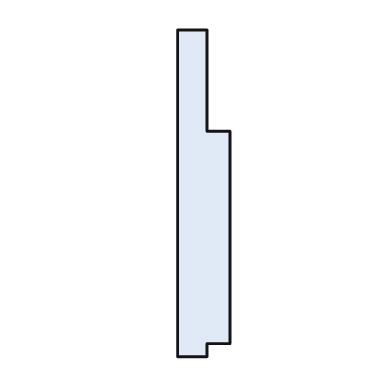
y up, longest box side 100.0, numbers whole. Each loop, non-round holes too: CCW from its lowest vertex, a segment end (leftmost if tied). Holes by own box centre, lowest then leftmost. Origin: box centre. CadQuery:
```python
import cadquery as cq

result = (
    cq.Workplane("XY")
    .moveTo(-8.0, -50.0)
    .lineTo(1.0, -50.0)
    .lineTo(1.0, -46.0)
    .lineTo(8.0, -46.0)
    .lineTo(8.0, 19.0)
    .lineTo(1.0, 19.0)
    .lineTo(1.0, 50.0)
    .lineTo(-8.0, 50.0)
    .close()
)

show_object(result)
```